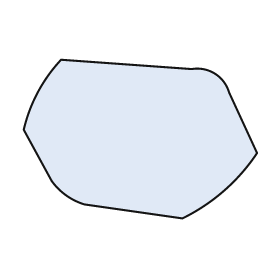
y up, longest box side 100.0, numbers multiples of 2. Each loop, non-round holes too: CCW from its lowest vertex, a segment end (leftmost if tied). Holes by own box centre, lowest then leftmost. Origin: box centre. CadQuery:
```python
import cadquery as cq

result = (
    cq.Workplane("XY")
    .moveTo(18.0, -34.0)
    .threePointArc((36.0, -22.0), (50.0, -6.0))
    .lineTo(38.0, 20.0)
    .threePointArc((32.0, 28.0), (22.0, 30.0))
    .lineTo(-34.0, 34.0)
    .threePointArc((-44.0, 20.0), (-50.0, 4.0))
    .lineTo(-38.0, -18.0)
    .threePointArc((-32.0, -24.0), (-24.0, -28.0))
    .close()
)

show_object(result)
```